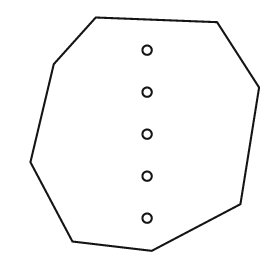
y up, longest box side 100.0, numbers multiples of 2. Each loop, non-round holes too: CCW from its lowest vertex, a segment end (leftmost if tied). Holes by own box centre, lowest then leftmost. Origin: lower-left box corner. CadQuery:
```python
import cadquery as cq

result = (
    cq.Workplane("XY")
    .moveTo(52.0, 0.0)
    .lineTo(90.0, 20.0)
    .lineTo(98.0, 70.0)
    .lineTo(80.0, 98.0)
    .lineTo(28.0, 100.0)
    .lineTo(10.0, 80.0)
    .lineTo(0.0, 38.0)
    .lineTo(18.0, 4.0)
    .close()
    .moveTo(50.0, 14.0)
    .circle(2.0)
    .moveTo(50.0, 32.0)
    .circle(2.0)
    .moveTo(50.0, 50.0)
    .circle(2.0)
    .moveTo(50.0, 68.0)
    .circle(2.0)
    .moveTo(50.0, 86.0)
    .circle(2.0)
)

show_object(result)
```